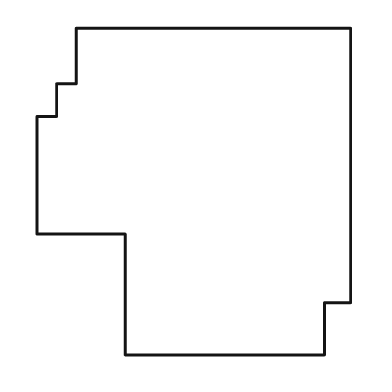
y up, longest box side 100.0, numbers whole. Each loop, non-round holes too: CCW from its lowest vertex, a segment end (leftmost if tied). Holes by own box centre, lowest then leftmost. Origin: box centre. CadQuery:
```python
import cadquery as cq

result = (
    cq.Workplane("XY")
    .moveTo(-21.0, -50.0)
    .lineTo(40.0, -50.0)
    .lineTo(40.0, -34.0)
    .lineTo(48.0, -34.0)
    .lineTo(48.0, 50.0)
    .lineTo(-36.0, 50.0)
    .lineTo(-36.0, 33.0)
    .lineTo(-42.0, 33.0)
    .lineTo(-42.0, 23.0)
    .lineTo(-48.0, 23.0)
    .lineTo(-48.0, -13.0)
    .lineTo(-21.0, -13.0)
    .close()
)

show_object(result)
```